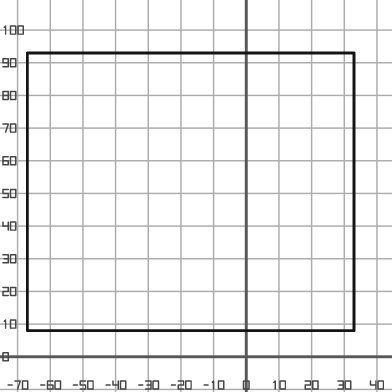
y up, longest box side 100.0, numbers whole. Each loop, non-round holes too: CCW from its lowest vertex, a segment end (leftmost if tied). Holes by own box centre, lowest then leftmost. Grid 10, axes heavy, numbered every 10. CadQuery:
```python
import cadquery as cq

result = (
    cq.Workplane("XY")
    .moveTo(-67.0, 8.0)
    .lineTo(33.0, 8.0)
    .lineTo(33.0, 93.0)
    .lineTo(-67.0, 93.0)
    .close()
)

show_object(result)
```